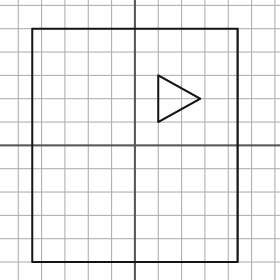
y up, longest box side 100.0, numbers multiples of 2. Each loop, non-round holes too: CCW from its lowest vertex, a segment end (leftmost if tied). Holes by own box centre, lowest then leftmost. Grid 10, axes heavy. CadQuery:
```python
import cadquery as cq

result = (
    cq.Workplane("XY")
    .moveTo(-44.0, -50.0)
    .lineTo(44.0, -50.0)
    .lineTo(44.0, 50.0)
    .lineTo(-44.0, 50.0)
    .close()
    .moveTo(10.0, 10.0)
    .lineTo(28.0, 20.0)
    .lineTo(10.0, 30.0)
    .close()
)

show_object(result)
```